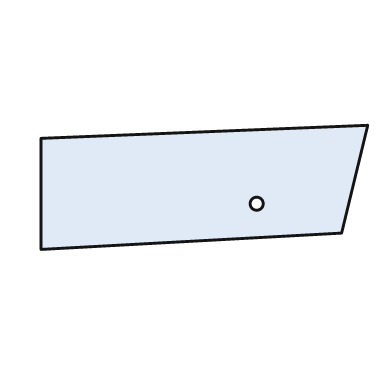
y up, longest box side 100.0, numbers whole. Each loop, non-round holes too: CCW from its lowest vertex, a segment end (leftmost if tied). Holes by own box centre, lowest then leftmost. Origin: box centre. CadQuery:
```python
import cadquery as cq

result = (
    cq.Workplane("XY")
    .moveTo(-50.0, -19.0)
    .lineTo(42.0, -14.0)
    .lineTo(50.0, 19.0)
    .lineTo(-50.0, 15.0)
    .close()
    .moveTo(16.0, -5.0)
    .circle(2.0)
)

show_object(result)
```